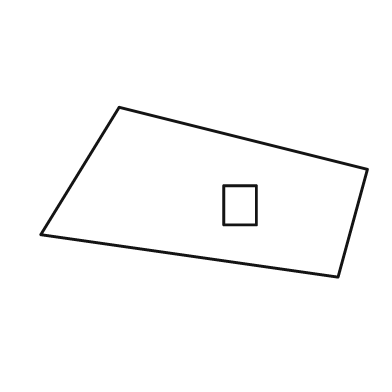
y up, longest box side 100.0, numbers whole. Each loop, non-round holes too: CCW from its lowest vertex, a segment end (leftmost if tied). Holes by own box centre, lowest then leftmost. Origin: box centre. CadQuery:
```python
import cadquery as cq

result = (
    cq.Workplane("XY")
    .moveTo(41.0, -26.0)
    .lineTo(50.0, 7.0)
    .lineTo(-26.0, 26.0)
    .lineTo(-50.0, -13.0)
    .close()
    .moveTo(6.0, -10.0)
    .lineTo(16.0, -10.0)
    .lineTo(16.0, 2.0)
    .lineTo(6.0, 2.0)
    .close()
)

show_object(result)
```